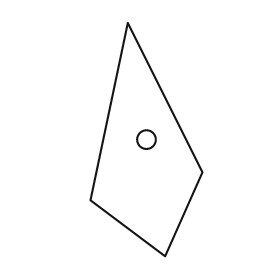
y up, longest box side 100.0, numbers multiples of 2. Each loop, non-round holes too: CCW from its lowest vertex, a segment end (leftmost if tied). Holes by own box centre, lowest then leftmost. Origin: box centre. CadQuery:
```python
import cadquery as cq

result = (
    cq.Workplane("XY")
    .moveTo(8.0, -50.0)
    .lineTo(24.0, -14.0)
    .lineTo(-8.0, 50.0)
    .lineTo(-24.0, -26.0)
    .close()
    .moveTo(0.0, 0.0)
    .circle(4.0)
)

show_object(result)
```